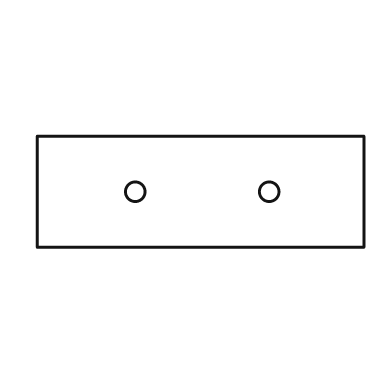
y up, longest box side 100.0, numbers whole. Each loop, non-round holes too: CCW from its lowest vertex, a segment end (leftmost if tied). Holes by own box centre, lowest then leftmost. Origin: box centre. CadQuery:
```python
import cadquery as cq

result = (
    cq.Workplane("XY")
    .moveTo(-50.0, -17.0)
    .lineTo(50.0, -17.0)
    .lineTo(50.0, 17.0)
    .lineTo(-50.0, 17.0)
    .close()
    .moveTo(-20.0, 0.0)
    .circle(3.0)
    .moveTo(21.0, 0.0)
    .circle(3.0)
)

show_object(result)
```